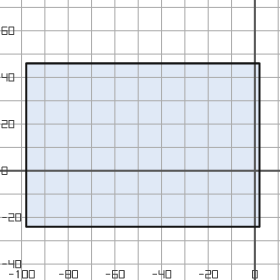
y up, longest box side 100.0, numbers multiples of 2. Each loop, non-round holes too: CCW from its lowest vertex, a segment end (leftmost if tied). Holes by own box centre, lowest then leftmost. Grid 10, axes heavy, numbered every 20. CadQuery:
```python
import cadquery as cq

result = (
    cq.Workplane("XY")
    .moveTo(-98.0, -24.0)
    .lineTo(2.0, -24.0)
    .lineTo(2.0, 46.0)
    .lineTo(-98.0, 46.0)
    .close()
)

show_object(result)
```